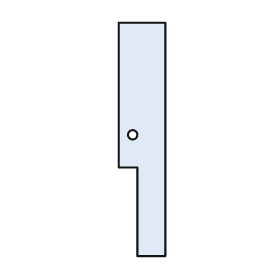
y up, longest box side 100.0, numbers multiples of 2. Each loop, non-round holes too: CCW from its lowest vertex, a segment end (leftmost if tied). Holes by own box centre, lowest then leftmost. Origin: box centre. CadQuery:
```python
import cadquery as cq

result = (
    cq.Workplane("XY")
    .moveTo(-2.0, -50.0)
    .lineTo(10.0, -50.0)
    .lineTo(10.0, 50.0)
    .lineTo(-10.0, 50.0)
    .lineTo(-10.0, -12.0)
    .lineTo(-2.0, -12.0)
    .close()
    .moveTo(-4.0, 2.0)
    .circle(2.0)
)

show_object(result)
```